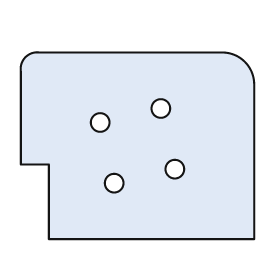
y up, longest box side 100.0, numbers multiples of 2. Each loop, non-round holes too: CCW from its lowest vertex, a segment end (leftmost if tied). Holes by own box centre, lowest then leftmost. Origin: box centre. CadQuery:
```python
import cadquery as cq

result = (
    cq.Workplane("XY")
    .moveTo(-38.0, -40.0)
    .lineTo(50.0, -40.0)
    .lineTo(50.0, 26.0)
    .threePointArc((46.0, 36.0), (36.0, 40.0))
    .lineTo(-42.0, 40.0)
    .threePointArc((-48.0, 38.0), (-50.0, 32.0))
    .lineTo(-50.0, -8.0)
    .lineTo(-38.0, -8.0)
    .close()
    .moveTo(-10.0, -16.0)
    .circle(4.0)
    .moveTo(16.0, -10.0)
    .circle(4.0)
    .moveTo(-16.0, 10.0)
    .circle(4.0)
    .moveTo(10.0, 16.0)
    .circle(4.0)
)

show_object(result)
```